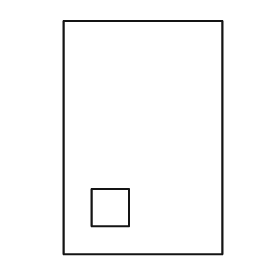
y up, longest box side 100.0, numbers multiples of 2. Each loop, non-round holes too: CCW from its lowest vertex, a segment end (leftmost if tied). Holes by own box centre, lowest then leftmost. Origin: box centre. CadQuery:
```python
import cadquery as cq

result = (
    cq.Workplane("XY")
    .moveTo(-34.0, -50.0)
    .lineTo(34.0, -50.0)
    .lineTo(34.0, 50.0)
    .lineTo(-34.0, 50.0)
    .close()
    .moveTo(-22.0, -38.0)
    .lineTo(-6.0, -38.0)
    .lineTo(-6.0, -22.0)
    .lineTo(-22.0, -22.0)
    .close()
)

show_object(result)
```